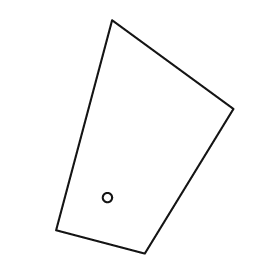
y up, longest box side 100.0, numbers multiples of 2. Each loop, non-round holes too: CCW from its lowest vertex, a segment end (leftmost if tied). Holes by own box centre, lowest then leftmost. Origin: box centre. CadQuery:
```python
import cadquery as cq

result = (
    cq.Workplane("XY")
    .moveTo(0.0, -50.0)
    .lineTo(38.0, 12.0)
    .lineTo(-14.0, 50.0)
    .lineTo(-38.0, -40.0)
    .close()
    .moveTo(-16.0, -26.0)
    .circle(2.0)
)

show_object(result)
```